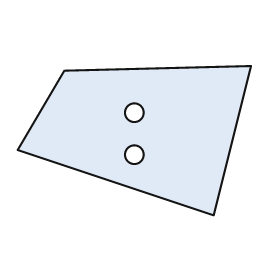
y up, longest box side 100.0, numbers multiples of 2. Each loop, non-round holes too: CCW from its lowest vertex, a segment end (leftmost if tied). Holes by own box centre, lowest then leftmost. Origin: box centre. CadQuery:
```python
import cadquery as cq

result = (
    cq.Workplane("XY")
    .moveTo(34.0, -32.0)
    .lineTo(50.0, 32.0)
    .lineTo(-30.0, 30.0)
    .lineTo(-50.0, -4.0)
    .close()
    .moveTo(0.0, -6.0)
    .circle(4.0)
    .moveTo(0.0, 12.0)
    .circle(4.0)
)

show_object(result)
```